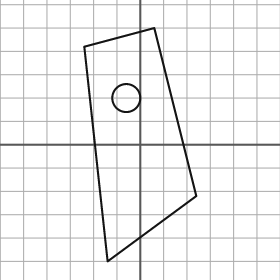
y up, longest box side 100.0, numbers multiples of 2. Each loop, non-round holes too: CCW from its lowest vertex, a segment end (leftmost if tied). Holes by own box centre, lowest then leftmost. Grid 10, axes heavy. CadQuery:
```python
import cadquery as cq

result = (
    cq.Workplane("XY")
    .moveTo(-14.0, -50.0)
    .lineTo(24.0, -22.0)
    .lineTo(6.0, 50.0)
    .lineTo(-24.0, 42.0)
    .close()
    .moveTo(-6.0, 20.0)
    .circle(6.0)
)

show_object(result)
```